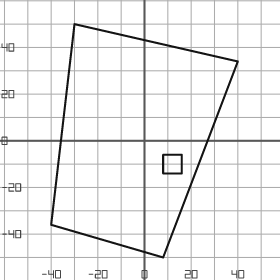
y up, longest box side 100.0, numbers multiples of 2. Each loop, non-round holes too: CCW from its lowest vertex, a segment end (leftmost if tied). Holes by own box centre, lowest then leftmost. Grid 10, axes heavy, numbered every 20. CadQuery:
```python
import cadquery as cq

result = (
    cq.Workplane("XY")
    .moveTo(8.0, -50.0)
    .lineTo(40.0, 34.0)
    .lineTo(-30.0, 50.0)
    .lineTo(-40.0, -36.0)
    .close()
    .moveTo(8.0, -14.0)
    .lineTo(16.0, -14.0)
    .lineTo(16.0, -6.0)
    .lineTo(8.0, -6.0)
    .close()
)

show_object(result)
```